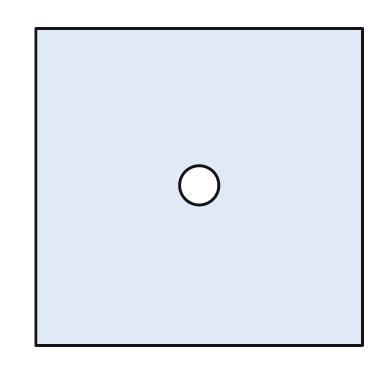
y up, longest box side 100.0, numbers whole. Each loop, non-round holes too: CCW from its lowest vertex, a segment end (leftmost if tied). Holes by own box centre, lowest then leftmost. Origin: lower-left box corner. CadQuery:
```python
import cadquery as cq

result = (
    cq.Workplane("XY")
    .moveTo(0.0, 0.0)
    .lineTo(100.0, 0.0)
    .lineTo(100.0, 97.0)
    .lineTo(0.0, 97.0)
    .close()
    .moveTo(50.0, 49.0)
    .circle(6.0)
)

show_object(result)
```